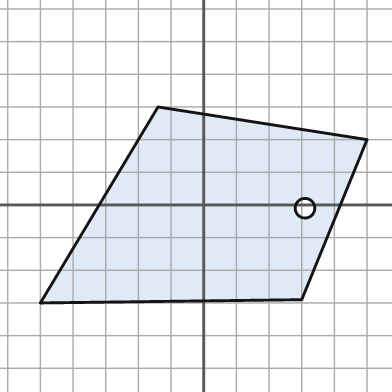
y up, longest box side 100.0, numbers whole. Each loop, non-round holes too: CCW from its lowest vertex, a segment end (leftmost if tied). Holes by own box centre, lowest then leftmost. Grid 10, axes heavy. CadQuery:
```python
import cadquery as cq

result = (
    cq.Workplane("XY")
    .moveTo(-50.0, -30.0)
    .lineTo(30.0, -29.0)
    .lineTo(50.0, 20.0)
    .lineTo(-14.0, 30.0)
    .close()
    .moveTo(31.0, -1.0)
    .circle(3.0)
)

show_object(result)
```